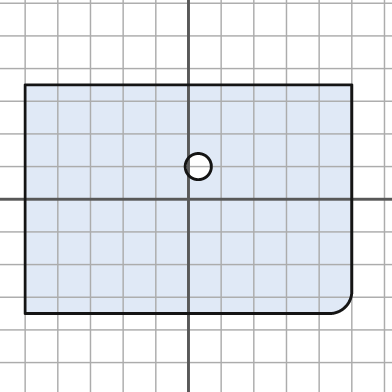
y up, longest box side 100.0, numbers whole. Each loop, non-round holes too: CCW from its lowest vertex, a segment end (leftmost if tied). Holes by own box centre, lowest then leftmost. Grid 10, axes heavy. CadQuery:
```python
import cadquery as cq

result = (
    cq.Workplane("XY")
    .moveTo(-50.0, -35.0)
    .lineTo(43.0, -35.0)
    .threePointArc((48.0, -33.0), (50.0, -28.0))
    .lineTo(50.0, 35.0)
    .lineTo(-50.0, 35.0)
    .close()
    .moveTo(3.0, 10.0)
    .circle(4.0)
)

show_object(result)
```